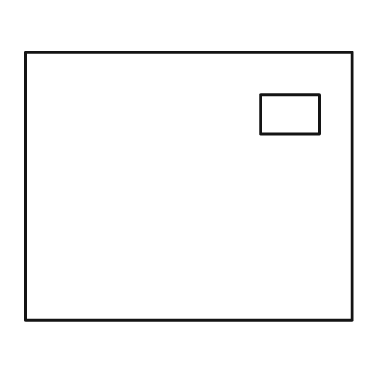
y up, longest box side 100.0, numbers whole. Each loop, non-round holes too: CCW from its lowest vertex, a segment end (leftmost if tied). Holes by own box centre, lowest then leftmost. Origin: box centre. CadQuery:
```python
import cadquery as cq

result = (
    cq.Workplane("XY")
    .moveTo(-50.0, -41.0)
    .lineTo(50.0, -41.0)
    .lineTo(50.0, 41.0)
    .lineTo(-50.0, 41.0)
    .close()
    .moveTo(22.0, 16.0)
    .lineTo(40.0, 16.0)
    .lineTo(40.0, 28.0)
    .lineTo(22.0, 28.0)
    .close()
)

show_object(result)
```